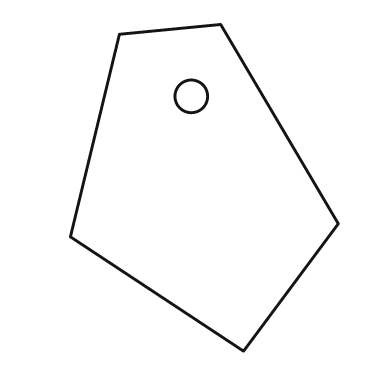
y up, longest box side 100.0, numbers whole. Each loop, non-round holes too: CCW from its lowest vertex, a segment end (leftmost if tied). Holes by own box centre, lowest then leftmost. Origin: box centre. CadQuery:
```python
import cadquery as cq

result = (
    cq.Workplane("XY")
    .moveTo(12.0, -50.0)
    .lineTo(41.0, -11.0)
    .lineTo(5.0, 50.0)
    .lineTo(-26.0, 47.0)
    .lineTo(-41.0, -15.0)
    .close()
    .moveTo(-4.0, 28.0)
    .circle(5.0)
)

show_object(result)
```